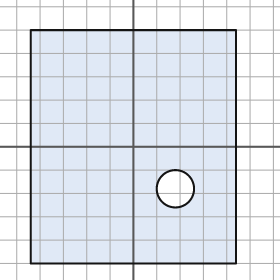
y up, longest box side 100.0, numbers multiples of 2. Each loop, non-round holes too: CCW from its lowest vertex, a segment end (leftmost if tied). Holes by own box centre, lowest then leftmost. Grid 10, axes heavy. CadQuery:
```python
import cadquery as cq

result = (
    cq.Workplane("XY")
    .moveTo(-44.0, -50.0)
    .lineTo(44.0, -50.0)
    .lineTo(44.0, 50.0)
    .lineTo(-44.0, 50.0)
    .close()
    .moveTo(18.0, -18.0)
    .circle(8.0)
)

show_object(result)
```